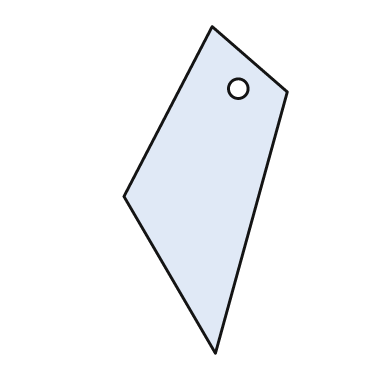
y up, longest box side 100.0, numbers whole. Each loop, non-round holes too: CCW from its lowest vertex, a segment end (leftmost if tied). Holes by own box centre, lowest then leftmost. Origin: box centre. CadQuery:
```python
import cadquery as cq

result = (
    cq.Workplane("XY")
    .moveTo(3.0, -50.0)
    .lineTo(25.0, 30.0)
    .lineTo(2.0, 50.0)
    .lineTo(-25.0, -2.0)
    .close()
    .moveTo(10.0, 31.0)
    .circle(3.0)
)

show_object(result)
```